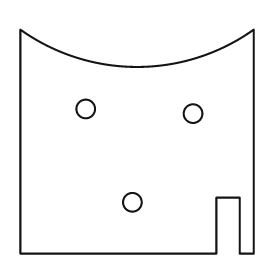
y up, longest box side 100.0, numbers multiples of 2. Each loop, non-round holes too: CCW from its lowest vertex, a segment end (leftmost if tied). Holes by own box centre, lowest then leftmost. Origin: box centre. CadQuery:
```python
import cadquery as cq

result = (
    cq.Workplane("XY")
    .moveTo(-50.0, -48.0)
    .lineTo(34.0, -48.0)
    .lineTo(34.0, -24.0)
    .lineTo(44.0, -24.0)
    .lineTo(44.0, -48.0)
    .lineTo(50.0, -48.0)
    .lineTo(50.0, 48.0)
    .threePointArc((0.0, 32.0), (-50.0, 48.0))
    .close()
    .moveTo(-2.0, -26.0)
    .circle(4.0)
    .moveTo(24.0, 12.0)
    .circle(4.0)
    .moveTo(-22.0, 14.0)
    .circle(4.0)
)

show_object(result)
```